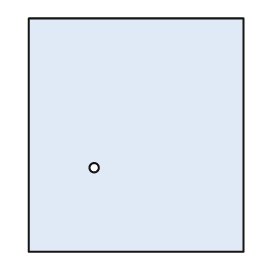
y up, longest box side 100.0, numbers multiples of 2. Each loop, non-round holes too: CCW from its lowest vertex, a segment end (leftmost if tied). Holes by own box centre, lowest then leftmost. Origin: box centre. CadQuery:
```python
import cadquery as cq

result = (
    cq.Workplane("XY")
    .moveTo(-46.0, -50.0)
    .lineTo(46.0, -50.0)
    .lineTo(46.0, 50.0)
    .lineTo(-46.0, 50.0)
    .close()
    .moveTo(-18.0, -14.0)
    .circle(2.0)
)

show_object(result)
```